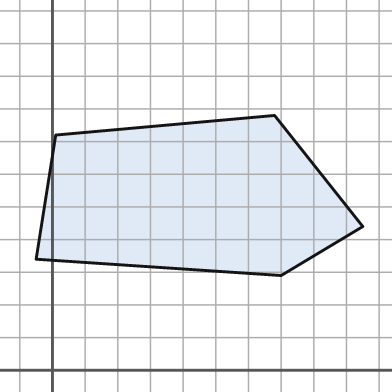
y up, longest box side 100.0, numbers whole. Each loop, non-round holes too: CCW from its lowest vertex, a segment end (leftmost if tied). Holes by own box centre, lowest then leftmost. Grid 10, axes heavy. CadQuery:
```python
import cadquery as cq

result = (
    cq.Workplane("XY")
    .moveTo(70.0, 29.0)
    .lineTo(95.0, 44.0)
    .lineTo(68.0, 78.0)
    .lineTo(1.0, 72.0)
    .lineTo(-5.0, 34.0)
    .close()
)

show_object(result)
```